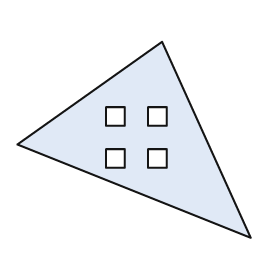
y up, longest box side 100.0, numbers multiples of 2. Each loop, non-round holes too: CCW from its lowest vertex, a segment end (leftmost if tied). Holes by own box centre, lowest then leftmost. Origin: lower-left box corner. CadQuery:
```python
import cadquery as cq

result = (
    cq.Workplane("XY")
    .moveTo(100.0, 0.0)
    .lineTo(62.0, 84.0)
    .lineTo(0.0, 40.0)
    .close()
    .moveTo(38.0, 30.0)
    .lineTo(46.0, 30.0)
    .lineTo(46.0, 38.0)
    .lineTo(38.0, 38.0)
    .close()
    .moveTo(56.0, 30.0)
    .lineTo(64.0, 30.0)
    .lineTo(64.0, 38.0)
    .lineTo(56.0, 38.0)
    .close()
    .moveTo(38.0, 48.0)
    .lineTo(46.0, 48.0)
    .lineTo(46.0, 56.0)
    .lineTo(38.0, 56.0)
    .close()
    .moveTo(56.0, 48.0)
    .lineTo(64.0, 48.0)
    .lineTo(64.0, 56.0)
    .lineTo(56.0, 56.0)
    .close()
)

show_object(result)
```